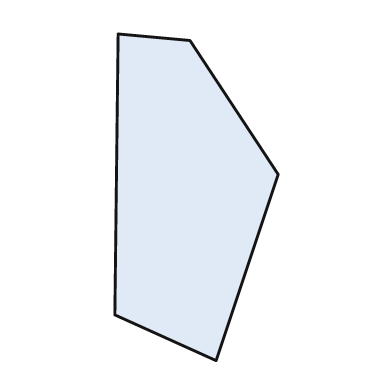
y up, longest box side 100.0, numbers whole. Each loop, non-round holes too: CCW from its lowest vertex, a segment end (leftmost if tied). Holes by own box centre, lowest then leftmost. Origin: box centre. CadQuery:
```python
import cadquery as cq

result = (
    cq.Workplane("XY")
    .moveTo(6.0, -50.0)
    .lineTo(25.0, 7.0)
    .lineTo(-2.0, 48.0)
    .lineTo(-24.0, 50.0)
    .lineTo(-25.0, -36.0)
    .close()
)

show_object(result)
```